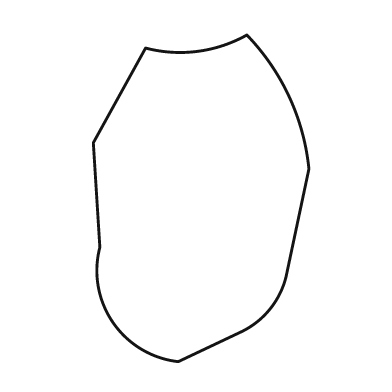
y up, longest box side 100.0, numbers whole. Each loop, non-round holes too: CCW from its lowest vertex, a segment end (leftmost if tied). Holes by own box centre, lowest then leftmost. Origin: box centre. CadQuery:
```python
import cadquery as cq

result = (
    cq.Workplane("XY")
    .moveTo(-7.0, -50.0)
    .lineTo(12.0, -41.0)
    .threePointArc((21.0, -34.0), (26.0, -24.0))
    .lineTo(33.0, 9.0)
    .threePointArc((27.0, 31.0), (14.0, 50.0))
    .threePointArc((-1.0, 45.0), (-17.0, 46.0))
    .lineTo(-33.0, 17.0)
    .lineTo(-31.0, -15.0)
    .threePointArc((-27.0, -38.0), (-7.0, -50.0))
    .close()
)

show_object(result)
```